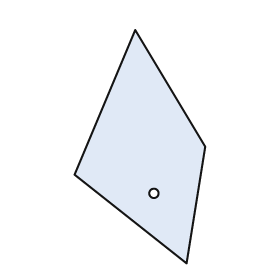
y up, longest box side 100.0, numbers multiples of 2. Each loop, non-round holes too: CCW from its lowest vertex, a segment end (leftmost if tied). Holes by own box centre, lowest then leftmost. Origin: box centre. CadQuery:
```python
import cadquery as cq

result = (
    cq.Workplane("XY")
    .moveTo(20.0, -50.0)
    .lineTo(28.0, 0.0)
    .lineTo(-2.0, 50.0)
    .lineTo(-28.0, -12.0)
    .close()
    .moveTo(6.0, -20.0)
    .circle(2.0)
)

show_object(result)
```